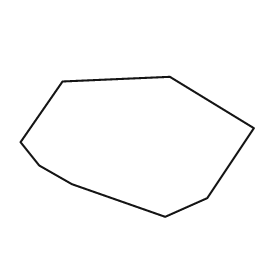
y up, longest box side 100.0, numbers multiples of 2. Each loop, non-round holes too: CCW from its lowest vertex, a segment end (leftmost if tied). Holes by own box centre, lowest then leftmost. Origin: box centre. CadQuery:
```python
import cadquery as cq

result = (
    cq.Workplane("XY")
    .moveTo(12.0, -30.0)
    .lineTo(30.0, -22.0)
    .lineTo(50.0, 8.0)
    .lineTo(14.0, 30.0)
    .lineTo(-32.0, 28.0)
    .lineTo(-50.0, 2.0)
    .lineTo(-42.0, -8.0)
    .lineTo(-28.0, -16.0)
    .close()
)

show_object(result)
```